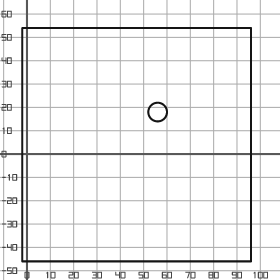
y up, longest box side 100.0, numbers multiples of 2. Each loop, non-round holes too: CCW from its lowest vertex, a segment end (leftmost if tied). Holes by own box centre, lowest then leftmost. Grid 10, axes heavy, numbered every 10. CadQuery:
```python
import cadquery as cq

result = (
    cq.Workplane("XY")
    .moveTo(-2.0, -46.0)
    .lineTo(96.0, -46.0)
    .lineTo(96.0, 54.0)
    .lineTo(-2.0, 54.0)
    .close()
    .moveTo(56.0, 18.0)
    .circle(4.0)
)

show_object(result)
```